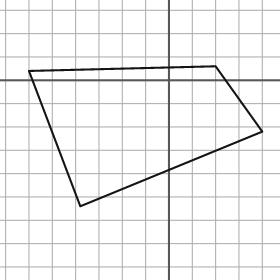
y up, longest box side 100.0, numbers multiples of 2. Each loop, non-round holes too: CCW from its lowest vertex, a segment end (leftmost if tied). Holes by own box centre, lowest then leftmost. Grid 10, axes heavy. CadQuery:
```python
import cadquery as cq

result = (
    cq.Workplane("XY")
    .moveTo(-38.0, -54.0)
    .lineTo(40.0, -22.0)
    .lineTo(20.0, 6.0)
    .lineTo(-60.0, 4.0)
    .close()
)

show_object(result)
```